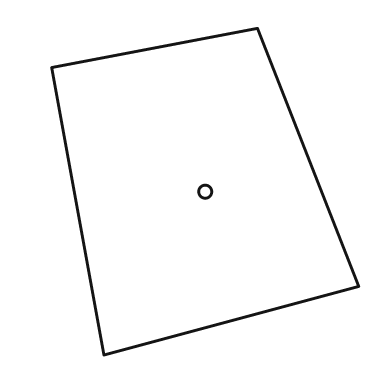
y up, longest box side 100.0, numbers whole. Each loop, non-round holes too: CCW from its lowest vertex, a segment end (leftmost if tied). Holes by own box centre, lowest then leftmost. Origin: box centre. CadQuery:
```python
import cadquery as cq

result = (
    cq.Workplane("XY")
    .moveTo(-31.0, -50.0)
    .lineTo(47.0, -29.0)
    .lineTo(16.0, 50.0)
    .lineTo(-47.0, 38.0)
    .close()
    .moveTo(0.0, 0.0)
    .circle(2.0)
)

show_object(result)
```